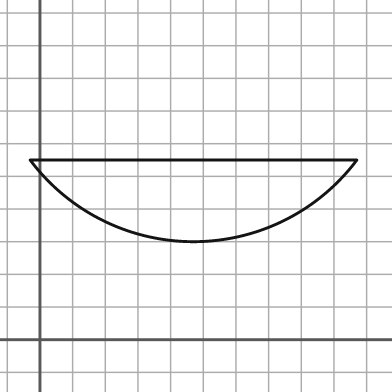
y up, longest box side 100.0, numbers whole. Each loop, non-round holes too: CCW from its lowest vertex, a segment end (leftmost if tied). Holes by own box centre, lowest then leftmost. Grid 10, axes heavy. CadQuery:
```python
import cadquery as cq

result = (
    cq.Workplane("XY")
    .moveTo(-3.0, 55.0)
    .threePointArc((47.0, 30.0), (97.0, 55.0))
    .close()
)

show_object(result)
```